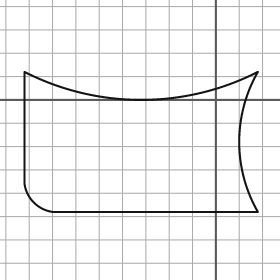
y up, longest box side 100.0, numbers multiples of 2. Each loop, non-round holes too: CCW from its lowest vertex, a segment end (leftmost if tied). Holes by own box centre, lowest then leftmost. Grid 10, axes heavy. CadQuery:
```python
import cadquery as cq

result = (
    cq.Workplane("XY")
    .moveTo(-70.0, -48.0)
    .lineTo(18.0, -48.0)
    .threePointArc((10.0, -18.0), (18.0, 12.0))
    .threePointArc((-32.0, 0.0), (-82.0, 12.0))
    .lineTo(-82.0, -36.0)
    .threePointArc((-78.0, -44.0), (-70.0, -48.0))
    .close()
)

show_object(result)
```